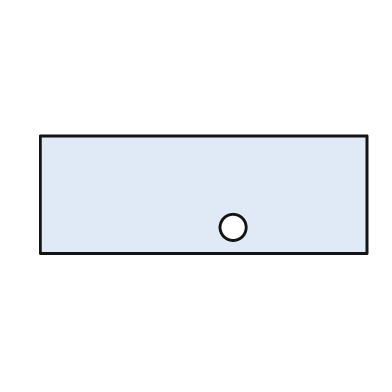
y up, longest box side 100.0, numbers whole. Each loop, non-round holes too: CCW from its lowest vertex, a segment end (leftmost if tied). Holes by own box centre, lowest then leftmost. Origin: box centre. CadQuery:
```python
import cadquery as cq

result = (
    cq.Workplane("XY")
    .moveTo(-50.0, -18.0)
    .lineTo(50.0, -18.0)
    .lineTo(50.0, 18.0)
    .lineTo(-50.0, 18.0)
    .close()
    .moveTo(9.0, -10.0)
    .circle(4.0)
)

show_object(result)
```